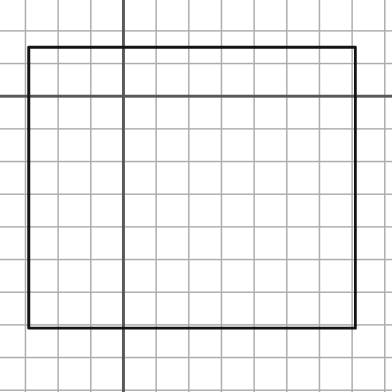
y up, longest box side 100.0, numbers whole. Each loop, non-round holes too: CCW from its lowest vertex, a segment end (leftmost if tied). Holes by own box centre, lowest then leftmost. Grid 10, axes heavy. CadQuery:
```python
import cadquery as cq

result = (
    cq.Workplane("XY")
    .moveTo(-29.0, -71.0)
    .lineTo(71.0, -71.0)
    .lineTo(71.0, 15.0)
    .lineTo(-29.0, 15.0)
    .close()
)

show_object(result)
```